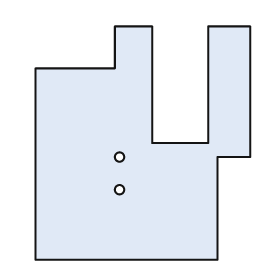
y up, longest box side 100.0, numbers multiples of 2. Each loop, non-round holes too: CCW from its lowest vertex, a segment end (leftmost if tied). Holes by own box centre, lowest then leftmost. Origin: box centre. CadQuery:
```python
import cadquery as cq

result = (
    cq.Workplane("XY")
    .moveTo(-46.0, -50.0)
    .lineTo(32.0, -50.0)
    .lineTo(32.0, -6.0)
    .lineTo(46.0, -6.0)
    .lineTo(46.0, 50.0)
    .lineTo(28.0, 50.0)
    .lineTo(28.0, 0.0)
    .lineTo(4.0, 0.0)
    .lineTo(4.0, 50.0)
    .lineTo(-12.0, 50.0)
    .lineTo(-12.0, 32.0)
    .lineTo(-46.0, 32.0)
    .close()
    .moveTo(-10.0, -20.0)
    .circle(2.0)
    .moveTo(-10.0, -6.0)
    .circle(2.0)
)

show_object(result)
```